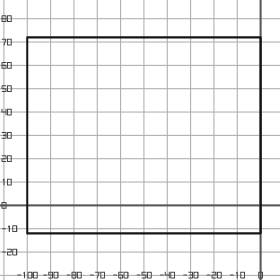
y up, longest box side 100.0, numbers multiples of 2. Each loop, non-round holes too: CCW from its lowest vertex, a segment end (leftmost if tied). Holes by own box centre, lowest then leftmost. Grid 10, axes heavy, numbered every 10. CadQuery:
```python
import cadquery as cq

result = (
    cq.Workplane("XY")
    .moveTo(-100.0, -12.0)
    .lineTo(0.0, -12.0)
    .lineTo(0.0, 72.0)
    .lineTo(-100.0, 72.0)
    .close()
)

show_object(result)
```